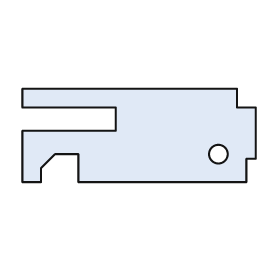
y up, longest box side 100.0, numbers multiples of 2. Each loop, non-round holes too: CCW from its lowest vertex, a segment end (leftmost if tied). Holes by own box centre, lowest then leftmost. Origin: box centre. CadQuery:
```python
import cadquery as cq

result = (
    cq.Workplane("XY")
    .moveTo(-50.0, -20.0)
    .lineTo(-42.0, -20.0)
    .lineTo(-42.0, -14.0)
    .lineTo(-36.0, -8.0)
    .lineTo(-26.0, -8.0)
    .lineTo(-26.0, -20.0)
    .lineTo(46.0, -20.0)
    .lineTo(46.0, -10.0)
    .lineTo(50.0, -10.0)
    .lineTo(50.0, 12.0)
    .lineTo(42.0, 12.0)
    .lineTo(42.0, 20.0)
    .lineTo(-50.0, 20.0)
    .lineTo(-50.0, 12.0)
    .lineTo(-10.0, 12.0)
    .lineTo(-10.0, 2.0)
    .lineTo(-50.0, 2.0)
    .close()
    .moveTo(34.0, -8.0)
    .circle(4.0)
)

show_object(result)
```